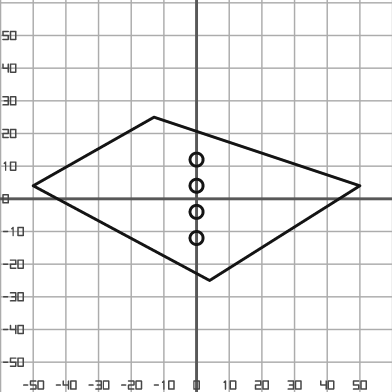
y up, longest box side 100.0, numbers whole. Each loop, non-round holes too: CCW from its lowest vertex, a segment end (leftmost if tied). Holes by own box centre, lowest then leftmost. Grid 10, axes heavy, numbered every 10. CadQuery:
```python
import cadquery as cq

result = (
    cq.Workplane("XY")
    .moveTo(4.0, -25.0)
    .lineTo(50.0, 4.0)
    .lineTo(-13.0, 25.0)
    .lineTo(-50.0, 4.0)
    .close()
    .moveTo(0.0, -12.0)
    .circle(2.0)
    .moveTo(0.0, -4.0)
    .circle(2.0)
    .moveTo(0.0, 4.0)
    .circle(2.0)
    .moveTo(0.0, 12.0)
    .circle(2.0)
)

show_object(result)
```